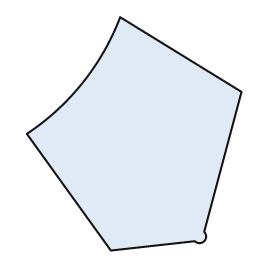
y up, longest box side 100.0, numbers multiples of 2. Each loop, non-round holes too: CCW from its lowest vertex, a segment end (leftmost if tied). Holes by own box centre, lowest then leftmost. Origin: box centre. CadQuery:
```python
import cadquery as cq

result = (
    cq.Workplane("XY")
    .moveTo(-10.0, -50.0)
    .lineTo(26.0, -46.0)
    .threePointArc((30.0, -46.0), (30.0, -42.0))
    .lineTo(46.0, 18.0)
    .lineTo(-6.0, 50.0)
    .threePointArc((-22.0, 22.0), (-46.0, 0.0))
    .close()
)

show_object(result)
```